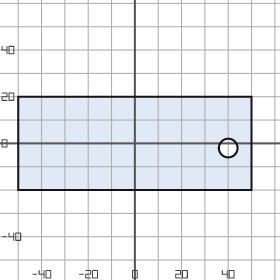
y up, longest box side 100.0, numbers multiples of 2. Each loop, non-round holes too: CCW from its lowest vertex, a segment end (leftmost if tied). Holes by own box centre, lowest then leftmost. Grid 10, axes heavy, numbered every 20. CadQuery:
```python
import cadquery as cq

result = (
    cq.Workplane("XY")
    .moveTo(-50.0, -20.0)
    .lineTo(50.0, -20.0)
    .lineTo(50.0, 20.0)
    .lineTo(-50.0, 20.0)
    .close()
    .moveTo(40.0, -2.0)
    .circle(4.0)
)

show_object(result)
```